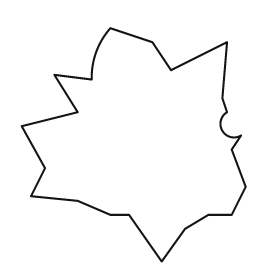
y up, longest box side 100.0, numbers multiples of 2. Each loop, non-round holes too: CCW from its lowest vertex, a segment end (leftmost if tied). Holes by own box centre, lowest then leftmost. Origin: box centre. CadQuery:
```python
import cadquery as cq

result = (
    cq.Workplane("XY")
    .moveTo(12.0, -50.0)
    .lineTo(22.0, -36.0)
    .lineTo(32.0, -30.0)
    .lineTo(42.0, -30.0)
    .lineTo(48.0, -18.0)
    .lineTo(42.0, -2.0)
    .lineTo(46.0, 4.0)
    .threePointArc((38.0, 6.0), (40.0, 14.0))
    .lineTo(38.0, 20.0)
    .lineTo(40.0, 44.0)
    .lineTo(16.0, 32.0)
    .lineTo(8.0, 44.0)
    .lineTo(-10.0, 50.0)
    .threePointArc((-16.0, 40.0), (-18.0, 28.0))
    .lineTo(-34.0, 30.0)
    .lineTo(-24.0, 14.0)
    .lineTo(-48.0, 8.0)
    .lineTo(-38.0, -10.0)
    .lineTo(-44.0, -22.0)
    .lineTo(-24.0, -24.0)
    .lineTo(-10.0, -30.0)
    .lineTo(-2.0, -30.0)
    .close()
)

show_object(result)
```